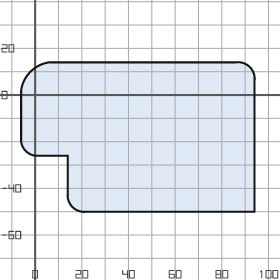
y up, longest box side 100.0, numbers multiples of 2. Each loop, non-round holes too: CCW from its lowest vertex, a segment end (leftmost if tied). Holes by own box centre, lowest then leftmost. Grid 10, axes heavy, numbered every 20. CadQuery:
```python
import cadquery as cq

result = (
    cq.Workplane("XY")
    .moveTo(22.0, -50.0)
    .lineTo(94.0, -50.0)
    .lineTo(94.0, 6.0)
    .threePointArc((92.0, 12.0), (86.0, 14.0))
    .lineTo(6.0, 14.0)
    .threePointArc((-2.0, 10.0), (-6.0, 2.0))
    .lineTo(-6.0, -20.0)
    .threePointArc((-4.0, -24.0), (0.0, -26.0))
    .lineTo(14.0, -26.0)
    .lineTo(14.0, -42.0)
    .threePointArc((16.0, -48.0), (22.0, -50.0))
    .close()
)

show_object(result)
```